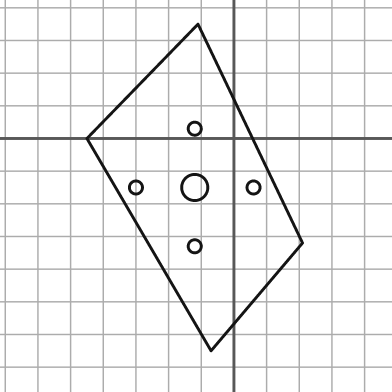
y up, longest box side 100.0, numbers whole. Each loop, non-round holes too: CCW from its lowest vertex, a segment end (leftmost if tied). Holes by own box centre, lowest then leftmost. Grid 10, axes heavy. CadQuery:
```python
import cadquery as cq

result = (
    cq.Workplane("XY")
    .moveTo(-7.0, -65.0)
    .lineTo(21.0, -32.0)
    .lineTo(-11.0, 35.0)
    .lineTo(-45.0, 0.0)
    .close()
    .moveTo(-12.0, -33.0)
    .circle(2.0)
    .moveTo(-30.0, -15.0)
    .circle(2.0)
    .moveTo(-12.0, -15.0)
    .circle(4.0)
    .moveTo(6.0, -15.0)
    .circle(2.0)
    .moveTo(-12.0, 3.0)
    .circle(2.0)
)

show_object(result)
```